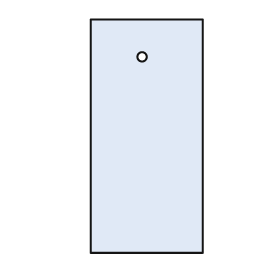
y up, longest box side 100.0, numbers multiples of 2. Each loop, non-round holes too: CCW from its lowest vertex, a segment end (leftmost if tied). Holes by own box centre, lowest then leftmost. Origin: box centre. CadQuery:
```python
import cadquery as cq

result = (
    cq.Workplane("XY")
    .moveTo(-24.0, -50.0)
    .lineTo(24.0, -50.0)
    .lineTo(24.0, 50.0)
    .lineTo(-24.0, 50.0)
    .close()
    .moveTo(-2.0, 34.0)
    .circle(2.0)
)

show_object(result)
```